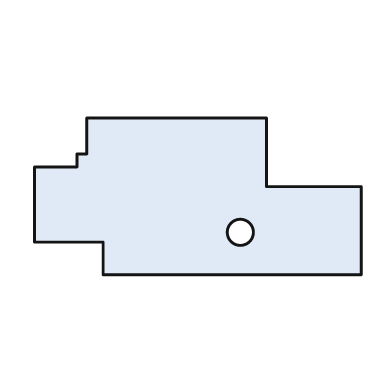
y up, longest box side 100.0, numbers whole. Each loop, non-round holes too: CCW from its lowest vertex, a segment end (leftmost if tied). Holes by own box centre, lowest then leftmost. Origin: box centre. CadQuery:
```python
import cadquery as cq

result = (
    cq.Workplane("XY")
    .moveTo(-29.0, -24.0)
    .lineTo(50.0, -24.0)
    .lineTo(50.0, 3.0)
    .lineTo(21.0, 3.0)
    .lineTo(21.0, 24.0)
    .lineTo(-34.0, 24.0)
    .lineTo(-34.0, 13.0)
    .lineTo(-37.0, 13.0)
    .lineTo(-37.0, 9.0)
    .lineTo(-50.0, 9.0)
    .lineTo(-50.0, -14.0)
    .lineTo(-29.0, -14.0)
    .close()
    .moveTo(13.0, -11.0)
    .circle(4.0)
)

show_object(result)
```